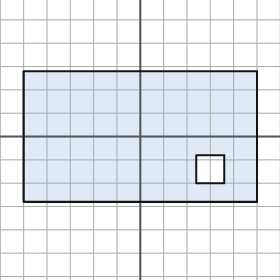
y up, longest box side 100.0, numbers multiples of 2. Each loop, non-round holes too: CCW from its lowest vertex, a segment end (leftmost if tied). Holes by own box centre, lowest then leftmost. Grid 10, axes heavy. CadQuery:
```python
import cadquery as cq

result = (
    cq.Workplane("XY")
    .moveTo(-50.0, -28.0)
    .lineTo(50.0, -28.0)
    .lineTo(50.0, 28.0)
    .lineTo(-50.0, 28.0)
    .close()
    .moveTo(24.0, -20.0)
    .lineTo(36.0, -20.0)
    .lineTo(36.0, -8.0)
    .lineTo(24.0, -8.0)
    .close()
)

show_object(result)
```